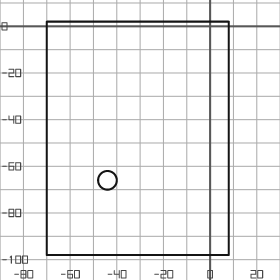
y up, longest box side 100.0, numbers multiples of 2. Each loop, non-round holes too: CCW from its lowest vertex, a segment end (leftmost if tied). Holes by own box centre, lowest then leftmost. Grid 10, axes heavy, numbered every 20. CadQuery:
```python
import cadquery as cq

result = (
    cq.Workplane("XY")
    .moveTo(-70.0, -98.0)
    .lineTo(8.0, -98.0)
    .lineTo(8.0, 2.0)
    .lineTo(-70.0, 2.0)
    .close()
    .moveTo(-44.0, -66.0)
    .circle(4.0)
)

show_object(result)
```